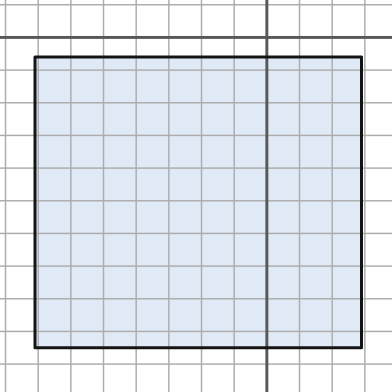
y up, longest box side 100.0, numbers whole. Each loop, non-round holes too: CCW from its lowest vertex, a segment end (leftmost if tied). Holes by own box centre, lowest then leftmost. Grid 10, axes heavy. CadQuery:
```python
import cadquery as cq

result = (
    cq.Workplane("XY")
    .moveTo(-71.0, -95.0)
    .lineTo(29.0, -95.0)
    .lineTo(29.0, -6.0)
    .lineTo(-71.0, -6.0)
    .close()
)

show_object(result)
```